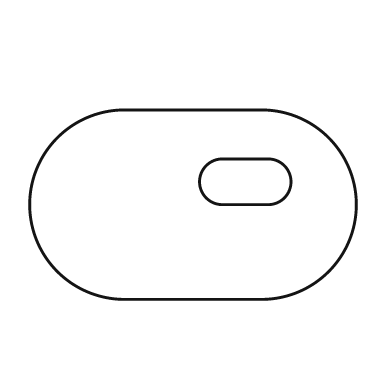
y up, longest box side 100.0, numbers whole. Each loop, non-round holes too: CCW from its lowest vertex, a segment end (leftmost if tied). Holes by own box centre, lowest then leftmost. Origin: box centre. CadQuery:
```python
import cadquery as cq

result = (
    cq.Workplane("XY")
    .moveTo(-21.0, -29.0)
    .lineTo(21.0, -29.0)
    .threePointArc((50.0, 0.0), (21.0, 29.0))
    .lineTo(-21.0, 29.0)
    .threePointArc((-50.0, 0.0), (-21.0, -29.0))
    .close()
    .moveTo(9.0, 0.0)
    .lineTo(23.0, 0.0)
    .threePointArc((30.0, 7.0), (23.0, 14.0))
    .lineTo(9.0, 14.0)
    .threePointArc((2.0, 7.0), (9.0, 0.0))
    .close()
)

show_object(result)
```